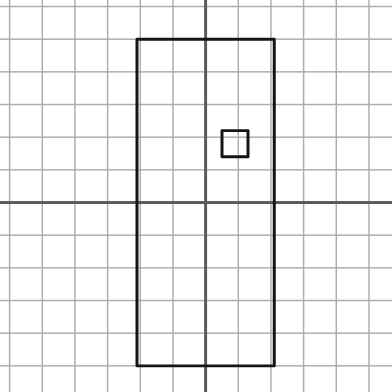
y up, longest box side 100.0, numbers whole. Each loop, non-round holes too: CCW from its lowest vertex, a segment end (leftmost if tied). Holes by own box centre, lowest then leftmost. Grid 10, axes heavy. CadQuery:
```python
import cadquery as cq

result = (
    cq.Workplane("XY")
    .moveTo(-21.0, -50.0)
    .lineTo(21.0, -50.0)
    .lineTo(21.0, 50.0)
    .lineTo(-21.0, 50.0)
    .close()
    .moveTo(5.0, 14.0)
    .lineTo(13.0, 14.0)
    .lineTo(13.0, 22.0)
    .lineTo(5.0, 22.0)
    .close()
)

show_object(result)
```